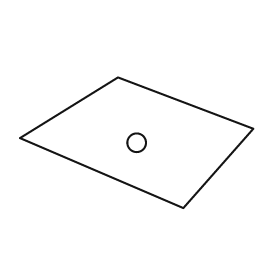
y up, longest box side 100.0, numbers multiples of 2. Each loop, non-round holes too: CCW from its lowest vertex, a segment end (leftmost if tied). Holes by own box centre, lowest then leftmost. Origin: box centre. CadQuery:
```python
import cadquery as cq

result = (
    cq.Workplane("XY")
    .moveTo(20.0, -28.0)
    .lineTo(50.0, 6.0)
    .lineTo(-8.0, 28.0)
    .lineTo(-50.0, 2.0)
    .close()
    .moveTo(0.0, 0.0)
    .circle(4.0)
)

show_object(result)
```